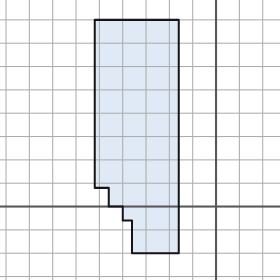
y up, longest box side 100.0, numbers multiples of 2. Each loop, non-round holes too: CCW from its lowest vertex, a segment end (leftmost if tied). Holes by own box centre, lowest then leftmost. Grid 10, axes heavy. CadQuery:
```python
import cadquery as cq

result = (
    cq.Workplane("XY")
    .moveTo(-36.0, -20.0)
    .lineTo(-16.0, -20.0)
    .lineTo(-16.0, 80.0)
    .lineTo(-52.0, 80.0)
    .lineTo(-52.0, 8.0)
    .lineTo(-46.0, 8.0)
    .lineTo(-46.0, 0.0)
    .lineTo(-40.0, 0.0)
    .lineTo(-40.0, -6.0)
    .lineTo(-36.0, -6.0)
    .close()
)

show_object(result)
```